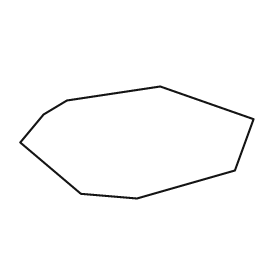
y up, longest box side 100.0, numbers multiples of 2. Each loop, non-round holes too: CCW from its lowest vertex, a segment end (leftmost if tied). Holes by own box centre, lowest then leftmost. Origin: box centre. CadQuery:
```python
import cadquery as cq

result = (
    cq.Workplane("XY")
    .moveTo(0.0, -24.0)
    .lineTo(42.0, -12.0)
    .lineTo(50.0, 10.0)
    .lineTo(10.0, 24.0)
    .lineTo(-30.0, 18.0)
    .lineTo(-40.0, 12.0)
    .lineTo(-50.0, 0.0)
    .lineTo(-24.0, -22.0)
    .close()
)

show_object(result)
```